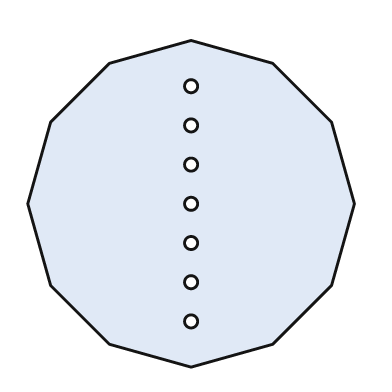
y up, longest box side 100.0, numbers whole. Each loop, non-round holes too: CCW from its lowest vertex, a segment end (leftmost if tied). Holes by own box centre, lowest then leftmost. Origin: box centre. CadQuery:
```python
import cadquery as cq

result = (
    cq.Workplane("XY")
    .moveTo(0.0, -50.0)
    .lineTo(25.0, -43.0)
    .lineTo(43.0, -25.0)
    .lineTo(50.0, 0.0)
    .lineTo(43.0, 25.0)
    .lineTo(25.0, 43.0)
    .lineTo(0.0, 50.0)
    .lineTo(-25.0, 43.0)
    .lineTo(-43.0, 25.0)
    .lineTo(-50.0, 0.0)
    .lineTo(-43.0, -25.0)
    .lineTo(-25.0, -43.0)
    .close()
    .moveTo(0.0, -36.0)
    .circle(2.0)
    .moveTo(0.0, -24.0)
    .circle(2.0)
    .moveTo(0.0, -12.0)
    .circle(2.0)
    .moveTo(0.0, 0.0)
    .circle(2.0)
    .moveTo(0.0, 12.0)
    .circle(2.0)
    .moveTo(0.0, 24.0)
    .circle(2.0)
    .moveTo(0.0, 36.0)
    .circle(2.0)
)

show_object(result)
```